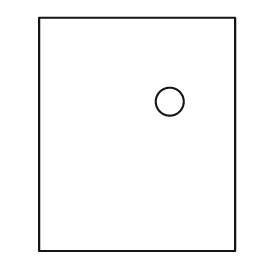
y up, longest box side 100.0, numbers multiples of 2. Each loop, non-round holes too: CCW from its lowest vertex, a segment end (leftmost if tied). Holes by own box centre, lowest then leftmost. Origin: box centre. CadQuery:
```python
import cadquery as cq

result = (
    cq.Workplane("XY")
    .moveTo(-42.0, -50.0)
    .lineTo(42.0, -50.0)
    .lineTo(42.0, 50.0)
    .lineTo(-42.0, 50.0)
    .close()
    .moveTo(14.0, 14.0)
    .circle(6.0)
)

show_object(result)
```